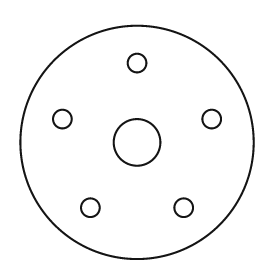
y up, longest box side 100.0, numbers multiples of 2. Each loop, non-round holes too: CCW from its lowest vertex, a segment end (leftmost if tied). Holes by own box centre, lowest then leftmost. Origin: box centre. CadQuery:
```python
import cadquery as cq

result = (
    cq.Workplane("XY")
    .moveTo(0.0, 0.0)
    .circle(50.0)
    .moveTo(-20.0, -28.0)
    .circle(4.0)
    .moveTo(20.0, -28.0)
    .circle(4.0)
    .moveTo(0.0, 0.0)
    .circle(10.0)
    .moveTo(-32.0, 10.0)
    .circle(4.0)
    .moveTo(32.0, 10.0)
    .circle(4.0)
    .moveTo(0.0, 34.0)
    .circle(4.0)
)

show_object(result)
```